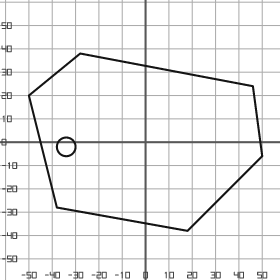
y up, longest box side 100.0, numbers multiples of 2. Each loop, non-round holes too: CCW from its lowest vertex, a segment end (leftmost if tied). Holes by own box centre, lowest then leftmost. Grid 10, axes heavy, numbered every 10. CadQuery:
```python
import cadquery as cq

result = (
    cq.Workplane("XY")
    .moveTo(18.0, -38.0)
    .lineTo(50.0, -6.0)
    .lineTo(46.0, 24.0)
    .lineTo(-28.0, 38.0)
    .lineTo(-50.0, 20.0)
    .lineTo(-38.0, -28.0)
    .close()
    .moveTo(-34.0, -2.0)
    .circle(4.0)
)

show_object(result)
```